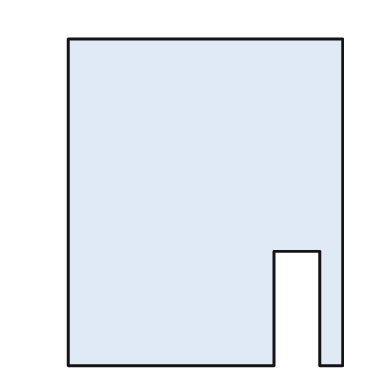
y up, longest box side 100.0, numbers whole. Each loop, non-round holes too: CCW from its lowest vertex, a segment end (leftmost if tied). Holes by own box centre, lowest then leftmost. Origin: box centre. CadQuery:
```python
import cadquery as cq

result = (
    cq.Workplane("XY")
    .moveTo(-42.0, -50.0)
    .lineTo(21.0, -50.0)
    .lineTo(21.0, -15.0)
    .lineTo(35.0, -15.0)
    .lineTo(35.0, -50.0)
    .lineTo(42.0, -50.0)
    .lineTo(42.0, 50.0)
    .lineTo(-42.0, 50.0)
    .close()
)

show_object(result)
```